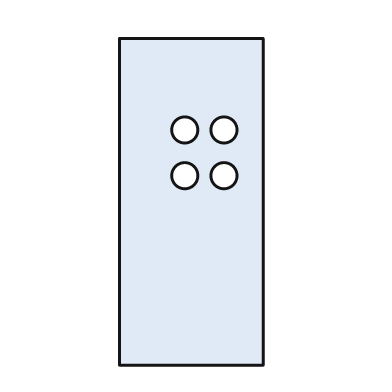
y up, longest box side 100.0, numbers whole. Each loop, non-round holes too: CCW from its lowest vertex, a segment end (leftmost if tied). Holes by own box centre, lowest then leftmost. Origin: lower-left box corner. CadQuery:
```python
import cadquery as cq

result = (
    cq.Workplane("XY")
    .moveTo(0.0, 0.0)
    .lineTo(44.0, 0.0)
    .lineTo(44.0, 100.0)
    .lineTo(0.0, 100.0)
    .close()
    .moveTo(20.0, 58.0)
    .circle(4.0)
    .moveTo(32.0, 58.0)
    .circle(4.0)
    .moveTo(20.0, 72.0)
    .circle(4.0)
    .moveTo(32.0, 72.0)
    .circle(4.0)
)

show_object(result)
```